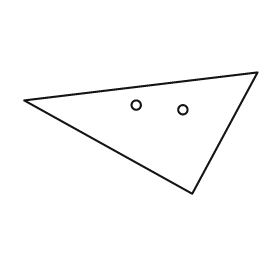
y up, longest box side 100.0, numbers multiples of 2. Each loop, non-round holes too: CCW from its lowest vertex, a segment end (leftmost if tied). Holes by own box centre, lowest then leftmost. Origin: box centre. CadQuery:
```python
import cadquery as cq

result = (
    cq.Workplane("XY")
    .moveTo(22.0, -26.0)
    .lineTo(50.0, 26.0)
    .lineTo(-50.0, 14.0)
    .close()
    .moveTo(18.0, 10.0)
    .circle(2.0)
    .moveTo(-2.0, 12.0)
    .circle(2.0)
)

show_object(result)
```